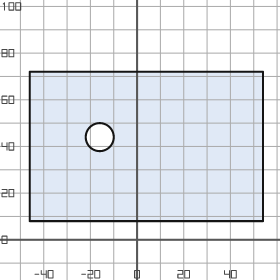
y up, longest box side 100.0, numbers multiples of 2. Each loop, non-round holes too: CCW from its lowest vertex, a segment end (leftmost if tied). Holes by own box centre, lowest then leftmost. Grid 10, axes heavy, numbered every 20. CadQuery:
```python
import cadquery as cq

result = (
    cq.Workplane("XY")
    .moveTo(-46.0, 8.0)
    .lineTo(54.0, 8.0)
    .lineTo(54.0, 72.0)
    .lineTo(-46.0, 72.0)
    .close()
    .moveTo(-16.0, 44.0)
    .circle(6.0)
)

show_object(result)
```